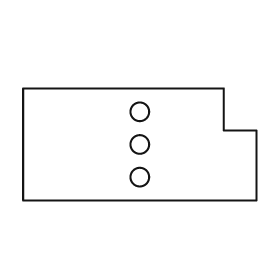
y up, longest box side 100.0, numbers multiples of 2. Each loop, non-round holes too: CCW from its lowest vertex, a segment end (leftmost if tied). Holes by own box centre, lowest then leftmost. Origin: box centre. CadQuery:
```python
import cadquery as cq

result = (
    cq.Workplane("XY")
    .moveTo(-50.0, -24.0)
    .lineTo(50.0, -24.0)
    .lineTo(50.0, 6.0)
    .lineTo(36.0, 6.0)
    .lineTo(36.0, 24.0)
    .lineTo(-50.0, 24.0)
    .close()
    .moveTo(0.0, -14.0)
    .circle(4.0)
    .moveTo(0.0, 0.0)
    .circle(4.0)
    .moveTo(0.0, 14.0)
    .circle(4.0)
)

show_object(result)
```